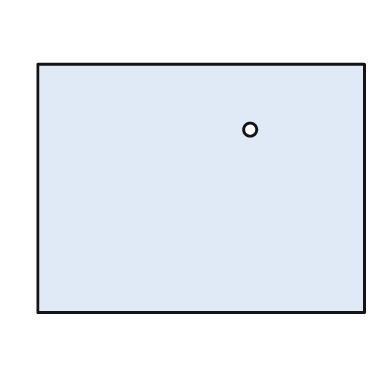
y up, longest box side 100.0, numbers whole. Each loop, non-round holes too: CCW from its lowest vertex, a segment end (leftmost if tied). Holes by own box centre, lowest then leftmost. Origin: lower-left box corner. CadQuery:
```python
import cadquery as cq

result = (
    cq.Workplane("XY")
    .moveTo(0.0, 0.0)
    .lineTo(100.0, 0.0)
    .lineTo(100.0, 76.0)
    .lineTo(0.0, 76.0)
    .close()
    .moveTo(65.0, 56.0)
    .circle(2.0)
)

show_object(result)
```